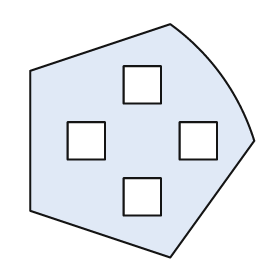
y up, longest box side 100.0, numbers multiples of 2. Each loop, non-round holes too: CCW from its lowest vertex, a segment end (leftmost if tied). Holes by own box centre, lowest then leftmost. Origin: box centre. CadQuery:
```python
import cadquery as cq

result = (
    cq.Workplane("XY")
    .moveTo(12.0, -50.0)
    .lineTo(48.0, 0.0)
    .threePointArc((34.0, 28.0), (12.0, 50.0))
    .lineTo(-48.0, 30.0)
    .lineTo(-48.0, -30.0)
    .close()
    .moveTo(-8.0, -32.0)
    .lineTo(8.0, -32.0)
    .lineTo(8.0, -16.0)
    .lineTo(-8.0, -16.0)
    .close()
    .moveTo(-32.0, -8.0)
    .lineTo(-16.0, -8.0)
    .lineTo(-16.0, 8.0)
    .lineTo(-32.0, 8.0)
    .close()
    .moveTo(16.0, -8.0)
    .lineTo(32.0, -8.0)
    .lineTo(32.0, 8.0)
    .lineTo(16.0, 8.0)
    .close()
    .moveTo(-8.0, 16.0)
    .lineTo(8.0, 16.0)
    .lineTo(8.0, 32.0)
    .lineTo(-8.0, 32.0)
    .close()
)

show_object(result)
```